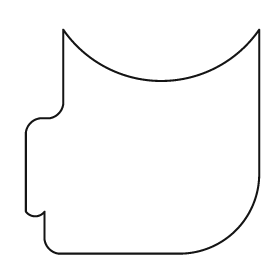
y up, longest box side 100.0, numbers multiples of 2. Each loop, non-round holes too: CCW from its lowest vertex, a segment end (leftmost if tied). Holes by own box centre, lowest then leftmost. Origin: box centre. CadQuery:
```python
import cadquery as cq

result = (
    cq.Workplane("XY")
    .moveTo(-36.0, -48.0)
    .lineTo(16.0, -48.0)
    .threePointArc((40.0, -38.0), (50.0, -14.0))
    .lineTo(50.0, 48.0)
    .threePointArc((8.0, 26.0), (-34.0, 48.0))
    .lineTo(-34.0, 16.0)
    .threePointArc((-36.0, 12.0), (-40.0, 10.0))
    .lineTo(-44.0, 10.0)
    .threePointArc((-48.0, 8.0), (-50.0, 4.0))
    .lineTo(-50.0, -30.0)
    .threePointArc((-46.0, -32.0), (-42.0, -30.0))
    .lineTo(-42.0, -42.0)
    .threePointArc((-40.0, -46.0), (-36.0, -48.0))
    .close()
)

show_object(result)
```